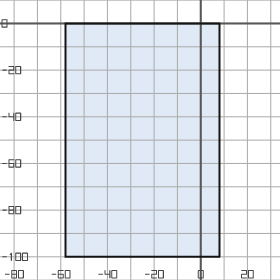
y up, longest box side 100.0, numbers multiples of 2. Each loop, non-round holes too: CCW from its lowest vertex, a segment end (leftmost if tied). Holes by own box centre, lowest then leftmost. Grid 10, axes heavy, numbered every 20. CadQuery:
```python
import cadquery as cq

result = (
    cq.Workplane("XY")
    .moveTo(-58.0, -100.0)
    .lineTo(8.0, -100.0)
    .lineTo(8.0, 0.0)
    .lineTo(-58.0, 0.0)
    .close()
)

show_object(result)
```